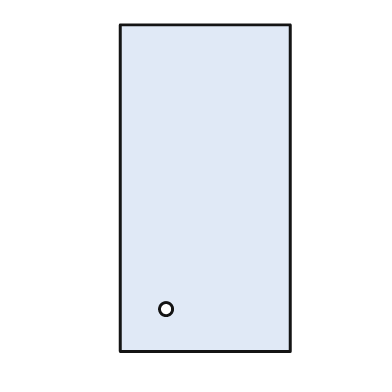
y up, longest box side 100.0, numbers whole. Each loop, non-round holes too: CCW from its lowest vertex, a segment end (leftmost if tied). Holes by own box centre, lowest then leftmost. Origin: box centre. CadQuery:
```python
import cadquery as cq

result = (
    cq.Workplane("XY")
    .moveTo(-26.0, -50.0)
    .lineTo(26.0, -50.0)
    .lineTo(26.0, 50.0)
    .lineTo(-26.0, 50.0)
    .close()
    .moveTo(-12.0, -37.0)
    .circle(2.0)
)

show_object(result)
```